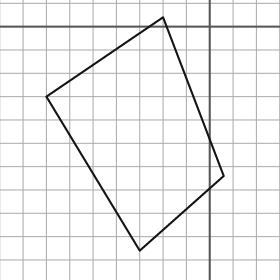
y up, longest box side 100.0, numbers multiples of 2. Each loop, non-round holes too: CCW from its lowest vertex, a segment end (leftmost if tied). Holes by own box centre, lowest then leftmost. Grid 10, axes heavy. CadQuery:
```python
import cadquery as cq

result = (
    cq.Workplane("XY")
    .moveTo(-30.0, -96.0)
    .lineTo(6.0, -64.0)
    .lineTo(-20.0, 4.0)
    .lineTo(-70.0, -30.0)
    .close()
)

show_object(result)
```